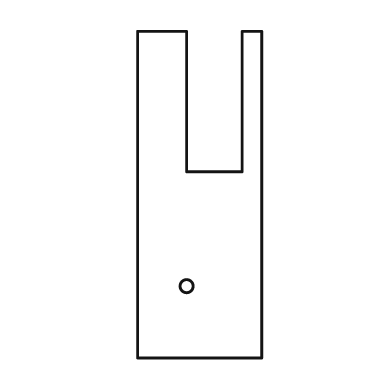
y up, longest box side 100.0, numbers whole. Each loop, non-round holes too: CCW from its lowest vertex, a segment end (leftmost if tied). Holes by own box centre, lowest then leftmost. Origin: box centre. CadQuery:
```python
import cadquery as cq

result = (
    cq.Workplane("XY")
    .moveTo(-19.0, -50.0)
    .lineTo(19.0, -50.0)
    .lineTo(19.0, 50.0)
    .lineTo(13.0, 50.0)
    .lineTo(13.0, 7.0)
    .lineTo(-4.0, 7.0)
    .lineTo(-4.0, 50.0)
    .lineTo(-19.0, 50.0)
    .close()
    .moveTo(-4.0, -28.0)
    .circle(2.0)
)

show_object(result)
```